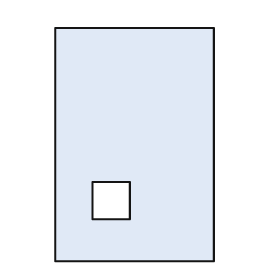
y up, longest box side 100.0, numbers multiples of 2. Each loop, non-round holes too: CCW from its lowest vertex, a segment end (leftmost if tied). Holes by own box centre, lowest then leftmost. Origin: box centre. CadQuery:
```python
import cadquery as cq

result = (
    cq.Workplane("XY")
    .moveTo(-34.0, -50.0)
    .lineTo(34.0, -50.0)
    .lineTo(34.0, 50.0)
    .lineTo(-34.0, 50.0)
    .close()
    .moveTo(-18.0, -32.0)
    .lineTo(-2.0, -32.0)
    .lineTo(-2.0, -16.0)
    .lineTo(-18.0, -16.0)
    .close()
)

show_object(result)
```